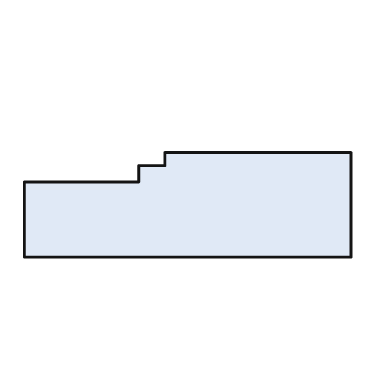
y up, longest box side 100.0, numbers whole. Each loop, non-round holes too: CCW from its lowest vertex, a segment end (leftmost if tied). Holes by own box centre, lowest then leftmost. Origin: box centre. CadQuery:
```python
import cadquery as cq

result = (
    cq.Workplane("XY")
    .moveTo(-50.0, -16.0)
    .lineTo(50.0, -16.0)
    .lineTo(50.0, 16.0)
    .lineTo(-7.0, 16.0)
    .lineTo(-7.0, 12.0)
    .lineTo(-15.0, 12.0)
    .lineTo(-15.0, 7.0)
    .lineTo(-50.0, 7.0)
    .close()
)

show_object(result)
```